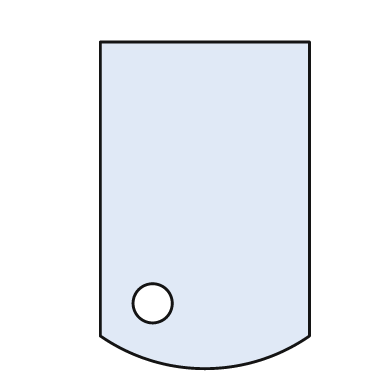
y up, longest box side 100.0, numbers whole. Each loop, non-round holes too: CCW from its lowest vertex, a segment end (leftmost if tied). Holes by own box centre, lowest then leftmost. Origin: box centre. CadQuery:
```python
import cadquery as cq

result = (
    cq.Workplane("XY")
    .moveTo(-32.0, -40.0)
    .threePointArc((0.0, -50.0), (32.0, -40.0))
    .lineTo(32.0, 50.0)
    .lineTo(-32.0, 50.0)
    .close()
    .moveTo(-16.0, -30.0)
    .circle(6.0)
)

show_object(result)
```